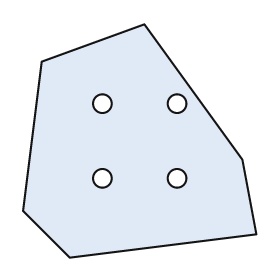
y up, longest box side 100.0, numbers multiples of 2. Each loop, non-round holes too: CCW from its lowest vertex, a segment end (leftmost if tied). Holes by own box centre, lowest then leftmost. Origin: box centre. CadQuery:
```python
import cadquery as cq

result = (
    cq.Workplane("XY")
    .moveTo(-30.0, -50.0)
    .lineTo(50.0, -40.0)
    .lineTo(44.0, -8.0)
    .lineTo(2.0, 50.0)
    .lineTo(-42.0, 34.0)
    .lineTo(-50.0, -30.0)
    .close()
    .moveTo(-16.0, -16.0)
    .circle(4.0)
    .moveTo(16.0, -16.0)
    .circle(4.0)
    .moveTo(-16.0, 16.0)
    .circle(4.0)
    .moveTo(16.0, 16.0)
    .circle(4.0)
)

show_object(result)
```